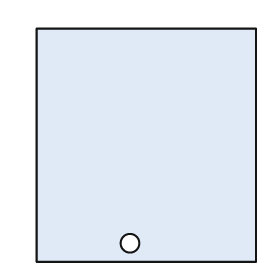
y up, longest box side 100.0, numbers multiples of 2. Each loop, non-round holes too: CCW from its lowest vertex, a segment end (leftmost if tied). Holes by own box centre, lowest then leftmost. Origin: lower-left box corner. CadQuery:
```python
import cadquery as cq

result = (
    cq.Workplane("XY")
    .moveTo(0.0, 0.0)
    .lineTo(94.0, 0.0)
    .lineTo(94.0, 100.0)
    .lineTo(0.0, 100.0)
    .close()
    .moveTo(40.0, 8.0)
    .circle(4.0)
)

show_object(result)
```